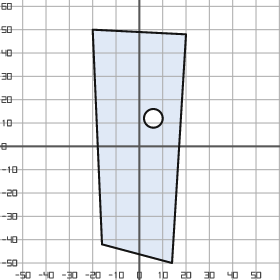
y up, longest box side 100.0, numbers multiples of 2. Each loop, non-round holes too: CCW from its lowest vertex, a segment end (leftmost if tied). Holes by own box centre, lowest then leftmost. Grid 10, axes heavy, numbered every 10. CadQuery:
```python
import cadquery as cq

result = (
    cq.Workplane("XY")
    .moveTo(14.0, -50.0)
    .lineTo(20.0, 48.0)
    .lineTo(-20.0, 50.0)
    .lineTo(-16.0, -42.0)
    .close()
    .moveTo(6.0, 12.0)
    .circle(4.0)
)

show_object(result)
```